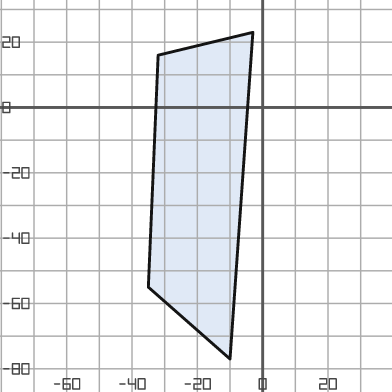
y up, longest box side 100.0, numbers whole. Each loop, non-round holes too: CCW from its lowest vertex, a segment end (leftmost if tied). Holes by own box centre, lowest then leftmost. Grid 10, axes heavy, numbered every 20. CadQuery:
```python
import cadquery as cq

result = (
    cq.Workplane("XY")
    .moveTo(-10.0, -77.0)
    .lineTo(-3.0, 23.0)
    .lineTo(-32.0, 16.0)
    .lineTo(-35.0, -55.0)
    .close()
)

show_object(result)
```